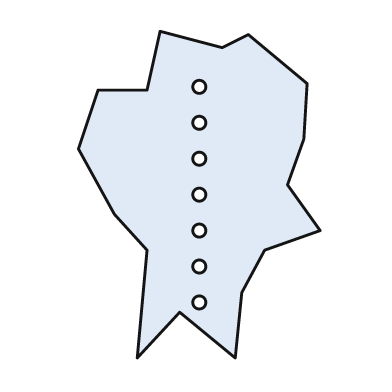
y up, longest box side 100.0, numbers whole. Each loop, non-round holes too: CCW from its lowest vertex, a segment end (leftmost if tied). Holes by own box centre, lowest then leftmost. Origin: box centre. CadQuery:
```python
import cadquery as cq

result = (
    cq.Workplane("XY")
    .moveTo(-19.0, -50.0)
    .lineTo(-6.0, -36.0)
    .lineTo(11.0, -50.0)
    .lineTo(13.0, -30.0)
    .lineTo(20.0, -17.0)
    .lineTo(37.0, -11.0)
    .lineTo(27.0, 3.0)
    .lineTo(32.0, 17.0)
    .lineTo(33.0, 34.0)
    .lineTo(15.0, 49.0)
    .lineTo(7.0, 45.0)
    .lineTo(-12.0, 50.0)
    .lineTo(-16.0, 32.0)
    .lineTo(-31.0, 32.0)
    .lineTo(-37.0, 14.0)
    .lineTo(-26.0, -6.0)
    .lineTo(-16.0, -17.0)
    .close()
    .moveTo(0.0, -33.0)
    .circle(2.0)
    .moveTo(0.0, -22.0)
    .circle(2.0)
    .moveTo(0.0, -11.0)
    .circle(2.0)
    .moveTo(0.0, 0.0)
    .circle(2.0)
    .moveTo(0.0, 11.0)
    .circle(2.0)
    .moveTo(0.0, 22.0)
    .circle(2.0)
    .moveTo(0.0, 33.0)
    .circle(2.0)
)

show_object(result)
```